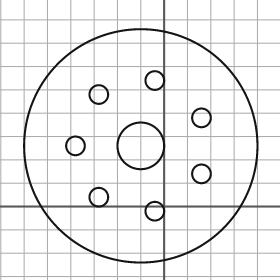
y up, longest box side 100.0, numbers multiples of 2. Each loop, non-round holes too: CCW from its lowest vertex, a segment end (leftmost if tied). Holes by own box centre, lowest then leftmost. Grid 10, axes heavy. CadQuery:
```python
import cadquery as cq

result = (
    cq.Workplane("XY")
    .moveTo(-10.0, 26.0)
    .circle(50.0)
    .moveTo(-4.0, -2.0)
    .circle(4.0)
    .moveTo(-28.0, 4.0)
    .circle(4.0)
    .moveTo(16.0, 14.0)
    .circle(4.0)
    .moveTo(-38.0, 26.0)
    .circle(4.0)
    .moveTo(-10.0, 26.0)
    .circle(10.0)
    .moveTo(16.0, 38.0)
    .circle(4.0)
    .moveTo(-28.0, 48.0)
    .circle(4.0)
    .moveTo(-4.0, 54.0)
    .circle(4.0)
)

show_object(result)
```